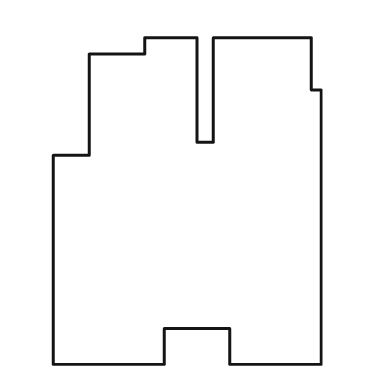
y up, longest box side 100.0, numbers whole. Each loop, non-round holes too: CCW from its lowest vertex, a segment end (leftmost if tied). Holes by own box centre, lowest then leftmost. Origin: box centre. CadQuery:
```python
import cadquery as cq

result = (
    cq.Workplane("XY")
    .moveTo(-41.0, -50.0)
    .lineTo(-7.0, -50.0)
    .lineTo(-7.0, -39.0)
    .lineTo(13.0, -39.0)
    .lineTo(13.0, -50.0)
    .lineTo(41.0, -50.0)
    .lineTo(41.0, 34.0)
    .lineTo(38.0, 34.0)
    .lineTo(38.0, 50.0)
    .lineTo(8.0, 50.0)
    .lineTo(8.0, 18.0)
    .lineTo(3.0, 18.0)
    .lineTo(3.0, 50.0)
    .lineTo(-13.0, 50.0)
    .lineTo(-13.0, 45.0)
    .lineTo(-30.0, 45.0)
    .lineTo(-30.0, 14.0)
    .lineTo(-41.0, 14.0)
    .close()
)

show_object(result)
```